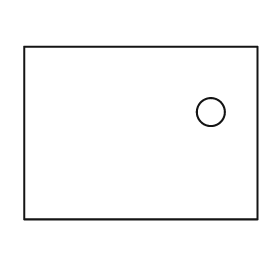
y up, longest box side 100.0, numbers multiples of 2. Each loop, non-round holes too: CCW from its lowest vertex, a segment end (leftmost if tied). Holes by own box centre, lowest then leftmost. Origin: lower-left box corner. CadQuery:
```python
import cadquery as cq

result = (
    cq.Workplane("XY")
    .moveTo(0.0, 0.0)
    .lineTo(100.0, 0.0)
    .lineTo(100.0, 74.0)
    .lineTo(0.0, 74.0)
    .close()
    .moveTo(80.0, 46.0)
    .circle(6.0)
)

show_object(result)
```